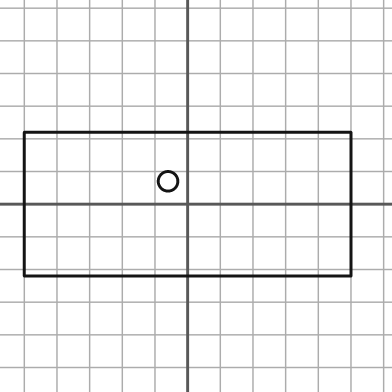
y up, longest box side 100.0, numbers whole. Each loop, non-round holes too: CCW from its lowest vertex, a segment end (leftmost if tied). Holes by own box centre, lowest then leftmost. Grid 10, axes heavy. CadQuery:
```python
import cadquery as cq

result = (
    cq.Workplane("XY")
    .moveTo(-50.0, -22.0)
    .lineTo(50.0, -22.0)
    .lineTo(50.0, 22.0)
    .lineTo(-50.0, 22.0)
    .close()
    .moveTo(-6.0, 7.0)
    .circle(3.0)
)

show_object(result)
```